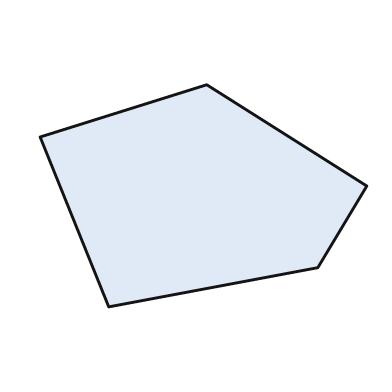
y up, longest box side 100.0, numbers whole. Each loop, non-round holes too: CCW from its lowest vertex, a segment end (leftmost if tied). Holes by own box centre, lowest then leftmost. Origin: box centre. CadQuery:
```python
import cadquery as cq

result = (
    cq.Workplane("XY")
    .moveTo(-29.0, -34.0)
    .lineTo(35.0, -22.0)
    .lineTo(50.0, 3.0)
    .lineTo(1.0, 34.0)
    .lineTo(-50.0, 18.0)
    .close()
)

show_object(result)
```